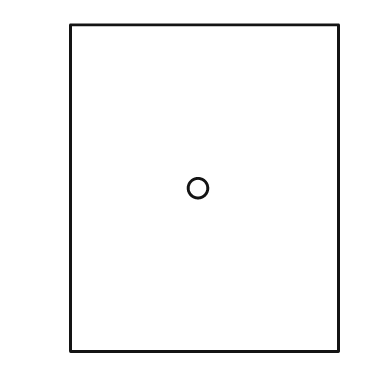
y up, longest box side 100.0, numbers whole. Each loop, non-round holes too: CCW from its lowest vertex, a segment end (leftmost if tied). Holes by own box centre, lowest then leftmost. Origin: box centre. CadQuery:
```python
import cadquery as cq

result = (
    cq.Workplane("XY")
    .moveTo(-41.0, -50.0)
    .lineTo(41.0, -50.0)
    .lineTo(41.0, 50.0)
    .lineTo(-41.0, 50.0)
    .close()
    .moveTo(-2.0, 0.0)
    .circle(3.0)
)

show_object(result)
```